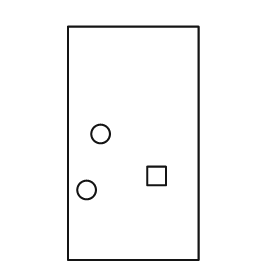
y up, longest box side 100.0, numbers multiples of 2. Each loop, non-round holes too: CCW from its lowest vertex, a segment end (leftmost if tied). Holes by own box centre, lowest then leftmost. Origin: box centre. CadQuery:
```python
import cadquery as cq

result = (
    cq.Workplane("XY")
    .moveTo(-28.0, -50.0)
    .lineTo(28.0, -50.0)
    .lineTo(28.0, 50.0)
    .lineTo(-28.0, 50.0)
    .close()
    .moveTo(-20.0, -20.0)
    .circle(4.0)
    .moveTo(6.0, -18.0)
    .lineTo(14.0, -18.0)
    .lineTo(14.0, -10.0)
    .lineTo(6.0, -10.0)
    .close()
    .moveTo(-14.0, 4.0)
    .circle(4.0)
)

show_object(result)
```